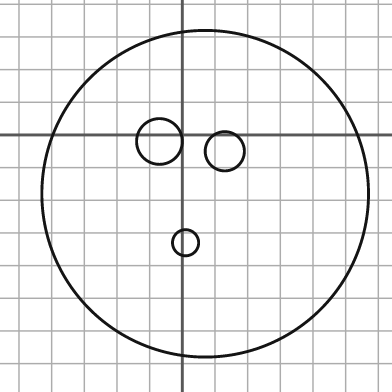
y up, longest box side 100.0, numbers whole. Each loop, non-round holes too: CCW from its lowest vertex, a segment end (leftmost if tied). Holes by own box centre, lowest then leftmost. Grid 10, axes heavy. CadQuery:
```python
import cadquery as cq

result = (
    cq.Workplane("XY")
    .moveTo(7.0, -18.0)
    .circle(50.0)
    .moveTo(1.0, -33.0)
    .circle(4.0)
    .moveTo(13.0, -5.0)
    .circle(6.0)
    .moveTo(-7.0, -2.0)
    .circle(7.0)
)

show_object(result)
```